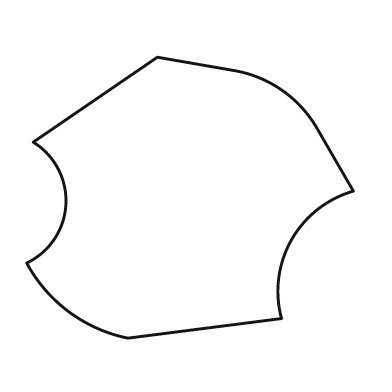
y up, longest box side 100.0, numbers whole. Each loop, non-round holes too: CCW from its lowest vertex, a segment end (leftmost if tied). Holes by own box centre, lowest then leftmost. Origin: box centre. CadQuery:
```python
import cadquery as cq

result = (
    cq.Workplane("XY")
    .moveTo(-19.0, -43.0)
    .lineTo(28.0, -37.0)
    .threePointArc((31.0, -13.0), (50.0, 2.0))
    .lineTo(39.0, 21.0)
    .threePointArc((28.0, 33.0), (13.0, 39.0))
    .lineTo(-10.0, 43.0)
    .lineTo(-48.0, 17.0)
    .threePointArc((-38.0, -2.0), (-50.0, -20.0))
    .threePointArc((-37.0, -35.0), (-19.0, -43.0))
    .close()
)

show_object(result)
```